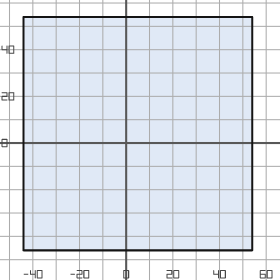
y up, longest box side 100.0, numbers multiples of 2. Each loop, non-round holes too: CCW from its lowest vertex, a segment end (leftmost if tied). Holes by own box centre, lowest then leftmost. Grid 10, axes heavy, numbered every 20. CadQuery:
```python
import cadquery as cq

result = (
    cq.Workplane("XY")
    .moveTo(-44.0, -46.0)
    .lineTo(54.0, -46.0)
    .lineTo(54.0, 54.0)
    .lineTo(-44.0, 54.0)
    .close()
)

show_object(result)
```